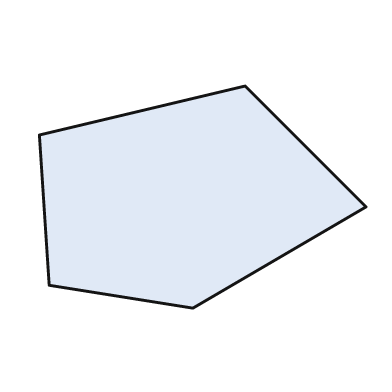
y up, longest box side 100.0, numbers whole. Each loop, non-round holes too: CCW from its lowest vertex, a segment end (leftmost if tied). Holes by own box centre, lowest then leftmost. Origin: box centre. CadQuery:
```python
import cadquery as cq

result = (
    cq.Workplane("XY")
    .moveTo(-3.0, -34.0)
    .lineTo(50.0, -3.0)
    .lineTo(13.0, 34.0)
    .lineTo(-50.0, 19.0)
    .lineTo(-47.0, -27.0)
    .close()
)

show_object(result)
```